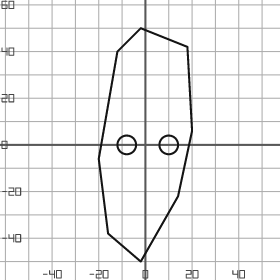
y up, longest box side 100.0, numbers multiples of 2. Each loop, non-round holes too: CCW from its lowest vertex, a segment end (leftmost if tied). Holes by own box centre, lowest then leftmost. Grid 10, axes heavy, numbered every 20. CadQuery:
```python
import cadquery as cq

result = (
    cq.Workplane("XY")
    .moveTo(-2.0, -50.0)
    .lineTo(14.0, -22.0)
    .lineTo(20.0, 6.0)
    .lineTo(18.0, 42.0)
    .lineTo(-2.0, 50.0)
    .lineTo(-12.0, 40.0)
    .lineTo(-20.0, -6.0)
    .lineTo(-16.0, -38.0)
    .close()
    .moveTo(-8.0, 0.0)
    .circle(4.0)
    .moveTo(10.0, 0.0)
    .circle(4.0)
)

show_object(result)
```